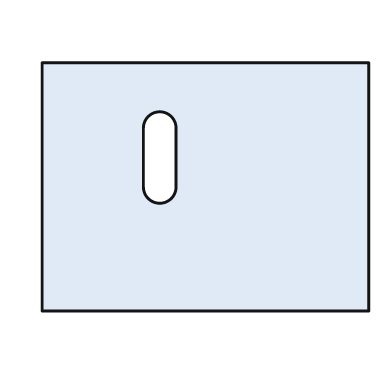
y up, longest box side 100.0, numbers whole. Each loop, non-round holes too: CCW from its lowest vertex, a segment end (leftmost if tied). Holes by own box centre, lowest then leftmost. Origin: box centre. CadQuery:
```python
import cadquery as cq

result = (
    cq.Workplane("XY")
    .moveTo(-50.0, -38.0)
    .lineTo(50.0, -38.0)
    .lineTo(50.0, 38.0)
    .lineTo(-50.0, 38.0)
    .close()
    .moveTo(-19.0, 0.0)
    .threePointArc((-14.0, -5.0), (-9.0, 0.0))
    .lineTo(-9.0, 18.0)
    .threePointArc((-14.0, 23.0), (-19.0, 18.0))
    .close()
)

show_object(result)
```